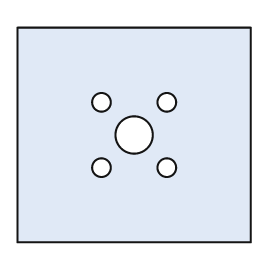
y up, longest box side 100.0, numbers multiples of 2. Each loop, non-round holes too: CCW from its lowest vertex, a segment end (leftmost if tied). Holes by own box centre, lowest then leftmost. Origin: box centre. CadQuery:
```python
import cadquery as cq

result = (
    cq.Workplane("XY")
    .moveTo(-50.0, -46.0)
    .lineTo(50.0, -46.0)
    .lineTo(50.0, 46.0)
    .lineTo(-50.0, 46.0)
    .close()
    .moveTo(-14.0, -14.0)
    .circle(4.0)
    .moveTo(14.0, -14.0)
    .circle(4.0)
    .moveTo(0.0, 0.0)
    .circle(8.0)
    .moveTo(-14.0, 14.0)
    .circle(4.0)
    .moveTo(14.0, 14.0)
    .circle(4.0)
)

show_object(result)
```